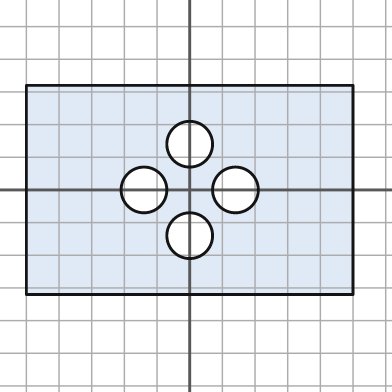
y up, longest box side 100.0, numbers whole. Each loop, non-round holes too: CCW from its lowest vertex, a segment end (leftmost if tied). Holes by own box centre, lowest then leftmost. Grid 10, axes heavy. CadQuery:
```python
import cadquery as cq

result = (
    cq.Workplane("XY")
    .moveTo(-50.0, -32.0)
    .lineTo(50.0, -32.0)
    .lineTo(50.0, 32.0)
    .lineTo(-50.0, 32.0)
    .close()
    .moveTo(0.0, -14.0)
    .circle(7.0)
    .moveTo(-14.0, 0.0)
    .circle(7.0)
    .moveTo(14.0, 0.0)
    .circle(7.0)
    .moveTo(0.0, 14.0)
    .circle(7.0)
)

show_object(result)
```